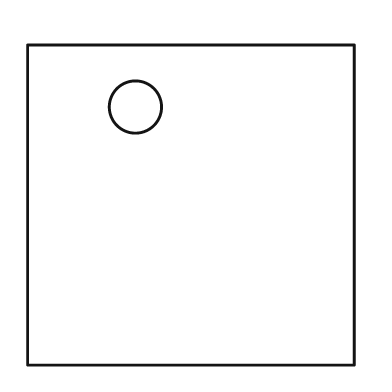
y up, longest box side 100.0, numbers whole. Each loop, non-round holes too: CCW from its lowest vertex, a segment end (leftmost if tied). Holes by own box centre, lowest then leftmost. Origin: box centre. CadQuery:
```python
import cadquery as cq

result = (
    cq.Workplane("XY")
    .moveTo(-50.0, -49.0)
    .lineTo(50.0, -49.0)
    .lineTo(50.0, 49.0)
    .lineTo(-50.0, 49.0)
    .close()
    .moveTo(-17.0, 30.0)
    .circle(8.0)
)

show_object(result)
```